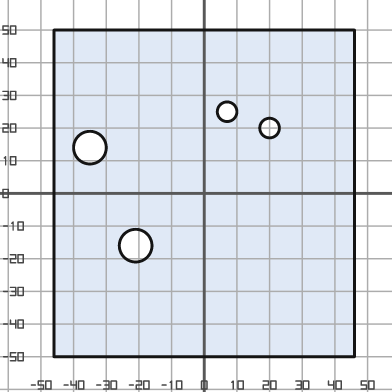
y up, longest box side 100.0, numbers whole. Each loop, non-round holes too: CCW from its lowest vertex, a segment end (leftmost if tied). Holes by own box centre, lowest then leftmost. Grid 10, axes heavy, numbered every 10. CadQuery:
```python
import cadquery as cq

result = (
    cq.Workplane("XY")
    .moveTo(-46.0, -50.0)
    .lineTo(46.0, -50.0)
    .lineTo(46.0, 50.0)
    .lineTo(-46.0, 50.0)
    .close()
    .moveTo(-21.0, -16.0)
    .circle(5.0)
    .moveTo(-35.0, 14.0)
    .circle(5.0)
    .moveTo(20.0, 20.0)
    .circle(3.0)
    .moveTo(7.0, 25.0)
    .circle(3.0)
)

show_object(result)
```